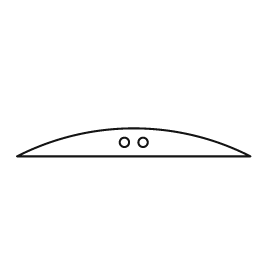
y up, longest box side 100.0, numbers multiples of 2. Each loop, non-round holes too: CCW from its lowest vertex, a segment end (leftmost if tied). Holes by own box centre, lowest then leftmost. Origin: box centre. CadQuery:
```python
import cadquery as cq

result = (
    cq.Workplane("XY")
    .moveTo(-50.0, -6.0)
    .lineTo(50.0, -6.0)
    .threePointArc((0.0, 6.0), (-50.0, -6.0))
    .close()
    .moveTo(-4.0, 0.0)
    .circle(2.0)
    .moveTo(4.0, 0.0)
    .circle(2.0)
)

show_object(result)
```